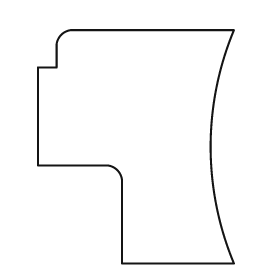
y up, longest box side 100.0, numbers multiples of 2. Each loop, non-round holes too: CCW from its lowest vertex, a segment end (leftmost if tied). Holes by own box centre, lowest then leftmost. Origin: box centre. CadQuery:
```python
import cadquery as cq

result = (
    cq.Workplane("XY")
    .moveTo(-6.0, -50.0)
    .lineTo(42.0, -50.0)
    .threePointArc((32.0, 0.0), (42.0, 50.0))
    .lineTo(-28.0, 50.0)
    .threePointArc((-32.0, 48.0), (-34.0, 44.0))
    .lineTo(-34.0, 34.0)
    .lineTo(-42.0, 34.0)
    .lineTo(-42.0, -8.0)
    .lineTo(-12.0, -8.0)
    .threePointArc((-8.0, -10.0), (-6.0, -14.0))
    .close()
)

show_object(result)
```